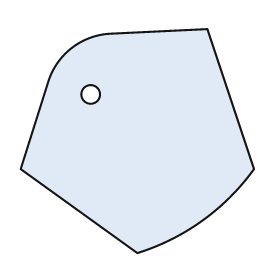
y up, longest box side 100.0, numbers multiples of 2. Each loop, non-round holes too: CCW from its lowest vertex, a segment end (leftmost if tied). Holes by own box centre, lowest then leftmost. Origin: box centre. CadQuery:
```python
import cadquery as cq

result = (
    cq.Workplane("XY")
    .moveTo(0.0, -48.0)
    .threePointArc((28.0, -34.0), (50.0, -12.0))
    .lineTo(30.0, 48.0)
    .lineTo(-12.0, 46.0)
    .threePointArc((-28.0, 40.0), (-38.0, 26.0))
    .lineTo(-50.0, -12.0)
    .close()
    .moveTo(-20.0, 20.0)
    .circle(4.0)
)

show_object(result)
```